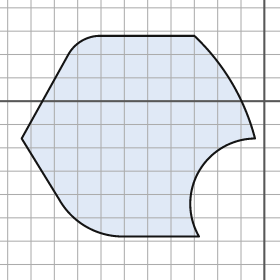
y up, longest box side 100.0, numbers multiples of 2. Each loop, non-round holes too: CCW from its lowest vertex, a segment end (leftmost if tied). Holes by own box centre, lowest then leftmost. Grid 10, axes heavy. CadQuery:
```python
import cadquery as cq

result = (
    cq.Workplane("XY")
    .moveTo(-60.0, -58.0)
    .lineTo(-28.0, -58.0)
    .threePointArc((-28.0, -30.0), (-4.0, -16.0))
    .threePointArc((-14.0, 8.0), (-30.0, 28.0))
    .lineTo(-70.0, 28.0)
    .threePointArc((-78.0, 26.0), (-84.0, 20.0))
    .lineTo(-104.0, -16.0)
    .lineTo(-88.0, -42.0)
    .threePointArc((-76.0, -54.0), (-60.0, -58.0))
    .close()
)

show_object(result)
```